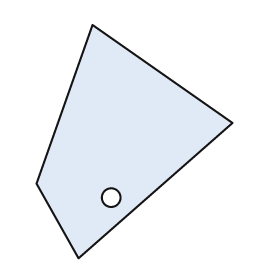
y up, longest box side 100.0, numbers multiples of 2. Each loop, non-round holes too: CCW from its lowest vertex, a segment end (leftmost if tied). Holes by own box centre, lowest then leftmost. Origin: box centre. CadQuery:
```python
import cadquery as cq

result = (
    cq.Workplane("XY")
    .moveTo(-24.0, -50.0)
    .lineTo(42.0, 8.0)
    .lineTo(-18.0, 50.0)
    .lineTo(-42.0, -18.0)
    .close()
    .moveTo(-10.0, -24.0)
    .circle(4.0)
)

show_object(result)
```